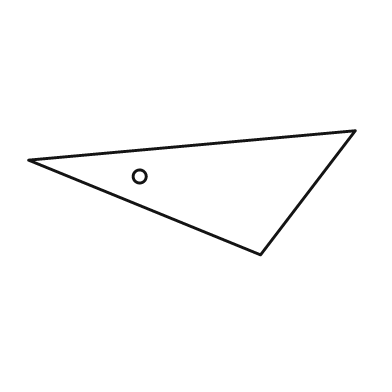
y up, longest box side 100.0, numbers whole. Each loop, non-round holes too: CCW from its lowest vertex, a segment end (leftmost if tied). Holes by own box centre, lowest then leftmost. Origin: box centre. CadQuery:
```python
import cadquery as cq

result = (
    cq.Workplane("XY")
    .moveTo(21.0, -19.0)
    .lineTo(50.0, 19.0)
    .lineTo(-50.0, 10.0)
    .close()
    .moveTo(-16.0, 5.0)
    .circle(2.0)
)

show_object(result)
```